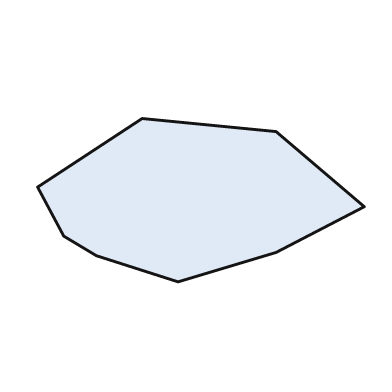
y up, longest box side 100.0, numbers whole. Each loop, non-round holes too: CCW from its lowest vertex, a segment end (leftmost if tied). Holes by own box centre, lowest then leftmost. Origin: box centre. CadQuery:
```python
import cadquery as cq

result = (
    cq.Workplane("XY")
    .moveTo(-7.0, -25.0)
    .lineTo(23.0, -16.0)
    .lineTo(50.0, -2.0)
    .lineTo(23.0, 21.0)
    .lineTo(-18.0, 25.0)
    .lineTo(-50.0, 4.0)
    .lineTo(-42.0, -11.0)
    .lineTo(-32.0, -17.0)
    .close()
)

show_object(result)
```